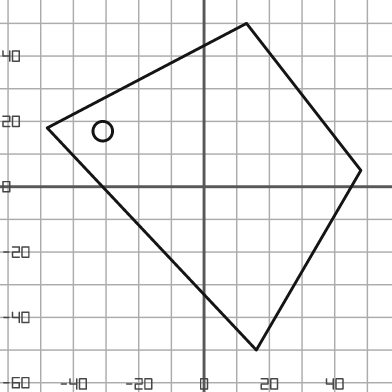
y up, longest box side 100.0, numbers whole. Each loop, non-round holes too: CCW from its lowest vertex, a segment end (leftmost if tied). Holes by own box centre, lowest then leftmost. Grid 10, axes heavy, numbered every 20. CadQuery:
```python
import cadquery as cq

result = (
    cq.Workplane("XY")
    .moveTo(16.0, -50.0)
    .lineTo(48.0, 5.0)
    .lineTo(13.0, 50.0)
    .lineTo(-48.0, 18.0)
    .close()
    .moveTo(-31.0, 17.0)
    .circle(3.0)
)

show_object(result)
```